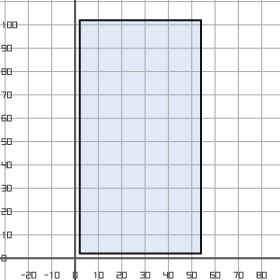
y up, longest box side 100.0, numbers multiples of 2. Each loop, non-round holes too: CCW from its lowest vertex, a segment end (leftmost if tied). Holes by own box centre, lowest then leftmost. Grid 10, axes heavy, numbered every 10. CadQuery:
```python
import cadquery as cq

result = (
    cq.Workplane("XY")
    .moveTo(2.0, 2.0)
    .lineTo(54.0, 2.0)
    .lineTo(54.0, 102.0)
    .lineTo(2.0, 102.0)
    .close()
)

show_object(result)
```